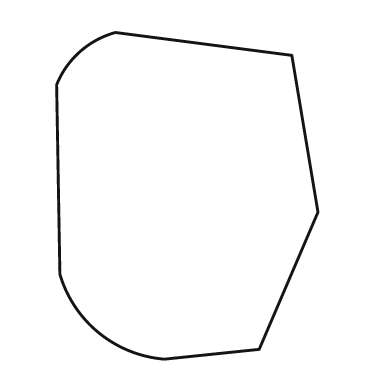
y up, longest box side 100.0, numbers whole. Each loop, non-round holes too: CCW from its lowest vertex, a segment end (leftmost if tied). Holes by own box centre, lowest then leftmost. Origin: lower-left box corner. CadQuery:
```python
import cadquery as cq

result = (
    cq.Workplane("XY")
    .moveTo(33.0, 0.0)
    .lineTo(62.0, 3.0)
    .lineTo(80.0, 45.0)
    .lineTo(72.0, 93.0)
    .lineTo(18.0, 100.0)
    .threePointArc((7.0, 94.0), (0.0, 84.0))
    .lineTo(1.0, 26.0)
    .threePointArc((13.0, 8.0), (33.0, 0.0))
    .close()
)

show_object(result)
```